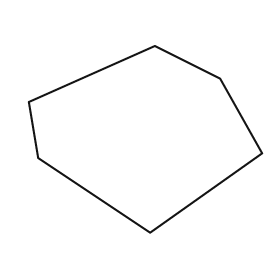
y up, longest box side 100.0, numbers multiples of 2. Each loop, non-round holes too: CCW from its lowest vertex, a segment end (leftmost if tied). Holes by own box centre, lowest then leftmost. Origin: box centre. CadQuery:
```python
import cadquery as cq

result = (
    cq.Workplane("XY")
    .moveTo(2.0, -40.0)
    .lineTo(50.0, -6.0)
    .lineTo(32.0, 26.0)
    .lineTo(4.0, 40.0)
    .lineTo(-50.0, 16.0)
    .lineTo(-46.0, -8.0)
    .close()
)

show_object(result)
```